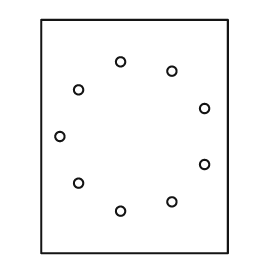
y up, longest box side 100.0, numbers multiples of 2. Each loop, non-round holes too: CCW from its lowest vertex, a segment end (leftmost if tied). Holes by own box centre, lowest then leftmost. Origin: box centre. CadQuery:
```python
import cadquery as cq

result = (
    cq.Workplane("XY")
    .moveTo(-40.0, -50.0)
    .lineTo(40.0, -50.0)
    .lineTo(40.0, 50.0)
    .lineTo(-40.0, 50.0)
    .close()
    .moveTo(-6.0, -32.0)
    .circle(2.0)
    .moveTo(16.0, -28.0)
    .circle(2.0)
    .moveTo(-24.0, -20.0)
    .circle(2.0)
    .moveTo(30.0, -12.0)
    .circle(2.0)
    .moveTo(-32.0, 0.0)
    .circle(2.0)
    .moveTo(30.0, 12.0)
    .circle(2.0)
    .moveTo(-24.0, 20.0)
    .circle(2.0)
    .moveTo(16.0, 28.0)
    .circle(2.0)
    .moveTo(-6.0, 32.0)
    .circle(2.0)
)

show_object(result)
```